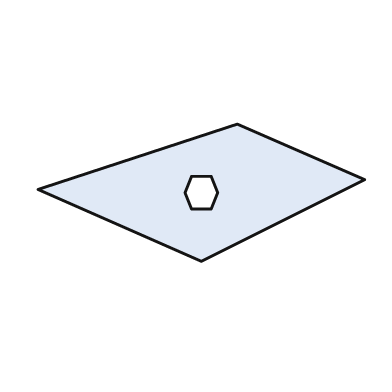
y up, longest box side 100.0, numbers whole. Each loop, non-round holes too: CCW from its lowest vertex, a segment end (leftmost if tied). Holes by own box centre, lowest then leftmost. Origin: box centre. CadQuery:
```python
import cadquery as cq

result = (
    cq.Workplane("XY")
    .moveTo(0.0, -21.0)
    .lineTo(50.0, 4.0)
    .lineTo(11.0, 21.0)
    .lineTo(-50.0, 1.0)
    .close()
    .moveTo(-3.0, -5.0)
    .lineTo(3.0, -5.0)
    .lineTo(5.0, 0.0)
    .lineTo(3.0, 5.0)
    .lineTo(-3.0, 5.0)
    .lineTo(-5.0, 0.0)
    .close()
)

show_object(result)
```